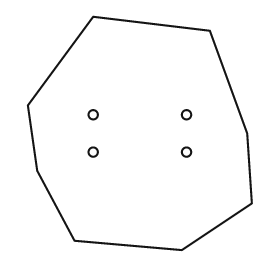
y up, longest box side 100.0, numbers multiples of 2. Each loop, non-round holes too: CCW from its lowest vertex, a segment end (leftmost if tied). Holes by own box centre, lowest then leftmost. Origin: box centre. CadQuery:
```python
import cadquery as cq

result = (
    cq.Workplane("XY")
    .moveTo(18.0, -50.0)
    .lineTo(48.0, -30.0)
    .lineTo(46.0, 0.0)
    .lineTo(30.0, 44.0)
    .lineTo(-20.0, 50.0)
    .lineTo(-48.0, 12.0)
    .lineTo(-44.0, -16.0)
    .lineTo(-28.0, -46.0)
    .close()
    .moveTo(-20.0, -8.0)
    .circle(2.0)
    .moveTo(20.0, -8.0)
    .circle(2.0)
    .moveTo(-20.0, 8.0)
    .circle(2.0)
    .moveTo(20.0, 8.0)
    .circle(2.0)
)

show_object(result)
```